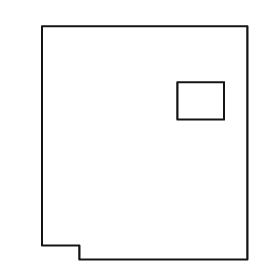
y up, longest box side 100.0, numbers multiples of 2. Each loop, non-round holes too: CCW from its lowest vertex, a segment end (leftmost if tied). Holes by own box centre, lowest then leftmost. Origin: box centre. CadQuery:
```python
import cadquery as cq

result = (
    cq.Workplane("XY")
    .moveTo(-28.0, -50.0)
    .lineTo(44.0, -50.0)
    .lineTo(44.0, 50.0)
    .lineTo(-44.0, 50.0)
    .lineTo(-44.0, -44.0)
    .lineTo(-28.0, -44.0)
    .close()
    .moveTo(14.0, 10.0)
    .lineTo(34.0, 10.0)
    .lineTo(34.0, 26.0)
    .lineTo(14.0, 26.0)
    .close()
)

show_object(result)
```